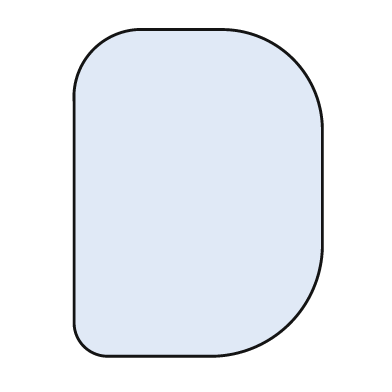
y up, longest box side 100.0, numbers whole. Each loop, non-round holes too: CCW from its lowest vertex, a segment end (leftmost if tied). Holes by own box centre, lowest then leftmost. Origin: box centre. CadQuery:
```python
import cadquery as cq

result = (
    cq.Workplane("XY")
    .moveTo(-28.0, -50.0)
    .lineTo(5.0, -50.0)
    .threePointArc((28.0, -40.0), (38.0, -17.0))
    .lineTo(38.0, 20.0)
    .threePointArc((29.0, 41.0), (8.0, 50.0))
    .lineTo(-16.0, 50.0)
    .threePointArc((-32.0, 44.0), (-38.0, 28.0))
    .lineTo(-38.0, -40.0)
    .threePointArc((-35.0, -47.0), (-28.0, -50.0))
    .close()
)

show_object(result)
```